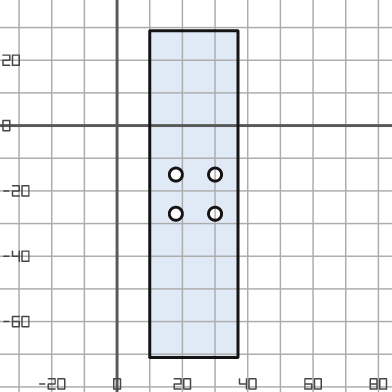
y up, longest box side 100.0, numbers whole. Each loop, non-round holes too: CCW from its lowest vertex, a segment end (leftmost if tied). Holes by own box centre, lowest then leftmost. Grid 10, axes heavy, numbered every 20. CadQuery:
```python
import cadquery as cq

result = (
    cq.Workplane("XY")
    .moveTo(10.0, -71.0)
    .lineTo(37.0, -71.0)
    .lineTo(37.0, 29.0)
    .lineTo(10.0, 29.0)
    .close()
    .moveTo(18.0, -27.0)
    .circle(2.0)
    .moveTo(30.0, -27.0)
    .circle(2.0)
    .moveTo(18.0, -15.0)
    .circle(2.0)
    .moveTo(30.0, -15.0)
    .circle(2.0)
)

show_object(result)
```